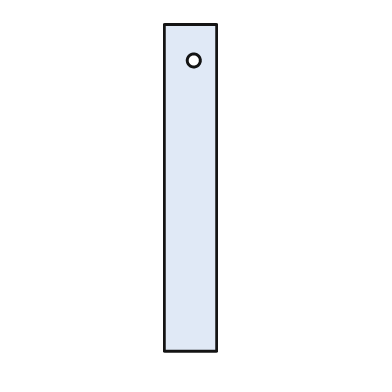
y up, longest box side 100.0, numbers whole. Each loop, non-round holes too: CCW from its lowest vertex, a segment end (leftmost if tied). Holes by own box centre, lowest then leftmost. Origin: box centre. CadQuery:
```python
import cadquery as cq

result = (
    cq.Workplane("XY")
    .moveTo(-8.0, -50.0)
    .lineTo(8.0, -50.0)
    .lineTo(8.0, 50.0)
    .lineTo(-8.0, 50.0)
    .close()
    .moveTo(1.0, 39.0)
    .circle(2.0)
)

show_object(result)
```